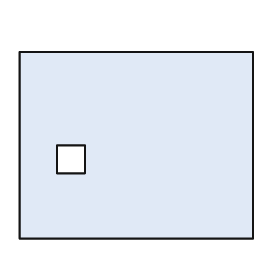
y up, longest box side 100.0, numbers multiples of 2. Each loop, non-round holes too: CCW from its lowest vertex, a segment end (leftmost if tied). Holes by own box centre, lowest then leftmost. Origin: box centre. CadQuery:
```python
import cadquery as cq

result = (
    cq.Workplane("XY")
    .moveTo(-50.0, -40.0)
    .lineTo(50.0, -40.0)
    .lineTo(50.0, 40.0)
    .lineTo(-50.0, 40.0)
    .close()
    .moveTo(-34.0, -12.0)
    .lineTo(-22.0, -12.0)
    .lineTo(-22.0, 0.0)
    .lineTo(-34.0, 0.0)
    .close()
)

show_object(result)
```